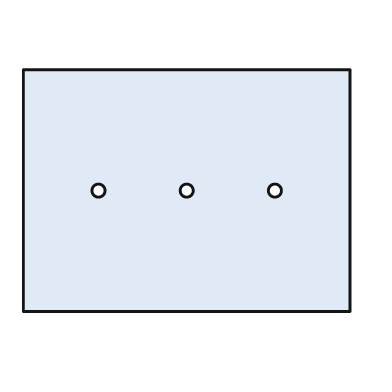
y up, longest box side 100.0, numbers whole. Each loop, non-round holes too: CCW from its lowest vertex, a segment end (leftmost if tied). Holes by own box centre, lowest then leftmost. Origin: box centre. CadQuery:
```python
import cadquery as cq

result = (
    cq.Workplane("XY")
    .moveTo(-50.0, -37.0)
    .lineTo(50.0, -37.0)
    .lineTo(50.0, 37.0)
    .lineTo(-50.0, 37.0)
    .close()
    .moveTo(-27.0, 0.0)
    .circle(2.0)
    .moveTo(0.0, 0.0)
    .circle(2.0)
    .moveTo(27.0, 0.0)
    .circle(2.0)
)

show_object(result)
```